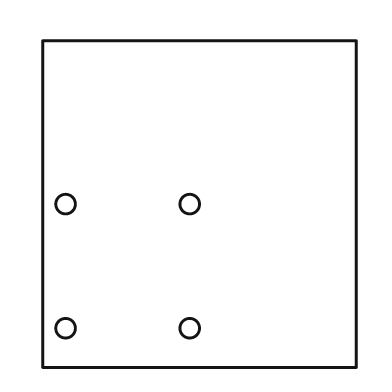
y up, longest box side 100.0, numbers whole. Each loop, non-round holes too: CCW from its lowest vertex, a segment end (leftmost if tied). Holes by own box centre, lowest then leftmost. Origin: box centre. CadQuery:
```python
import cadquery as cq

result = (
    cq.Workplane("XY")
    .moveTo(-48.0, -50.0)
    .lineTo(48.0, -50.0)
    .lineTo(48.0, 50.0)
    .lineTo(-48.0, 50.0)
    .close()
    .moveTo(-41.0, -38.0)
    .circle(3.0)
    .moveTo(-3.0, -38.0)
    .circle(3.0)
    .moveTo(-41.0, 0.0)
    .circle(3.0)
    .moveTo(-3.0, 0.0)
    .circle(3.0)
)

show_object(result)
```